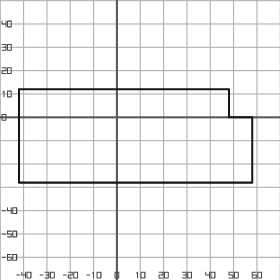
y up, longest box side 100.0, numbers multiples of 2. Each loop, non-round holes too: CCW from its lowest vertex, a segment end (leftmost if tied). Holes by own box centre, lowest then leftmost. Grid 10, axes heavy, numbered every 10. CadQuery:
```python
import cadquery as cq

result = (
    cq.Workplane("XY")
    .moveTo(-42.0, -28.0)
    .lineTo(58.0, -28.0)
    .lineTo(58.0, 0.0)
    .lineTo(48.0, 0.0)
    .lineTo(48.0, 12.0)
    .lineTo(-42.0, 12.0)
    .close()
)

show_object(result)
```